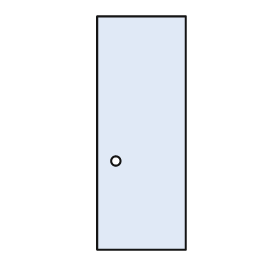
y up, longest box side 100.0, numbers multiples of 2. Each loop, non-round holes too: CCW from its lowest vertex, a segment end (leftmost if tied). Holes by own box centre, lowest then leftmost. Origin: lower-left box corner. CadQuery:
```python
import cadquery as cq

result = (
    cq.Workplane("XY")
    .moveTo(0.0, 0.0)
    .lineTo(38.0, 0.0)
    .lineTo(38.0, 100.0)
    .lineTo(0.0, 100.0)
    .close()
    .moveTo(8.0, 38.0)
    .circle(2.0)
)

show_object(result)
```